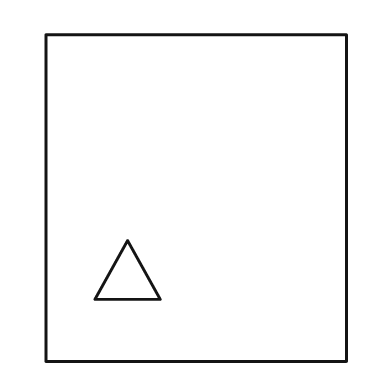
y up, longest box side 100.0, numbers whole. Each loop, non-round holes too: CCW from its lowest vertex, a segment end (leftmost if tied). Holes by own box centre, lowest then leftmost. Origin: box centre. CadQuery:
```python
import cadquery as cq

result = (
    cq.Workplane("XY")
    .moveTo(-46.0, -50.0)
    .lineTo(46.0, -50.0)
    .lineTo(46.0, 50.0)
    .lineTo(-46.0, 50.0)
    .close()
    .moveTo(-31.0, -31.0)
    .lineTo(-11.0, -31.0)
    .lineTo(-21.0, -13.0)
    .close()
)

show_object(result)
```